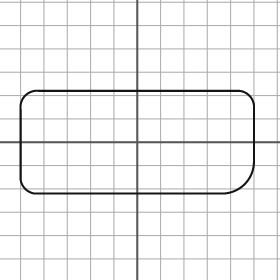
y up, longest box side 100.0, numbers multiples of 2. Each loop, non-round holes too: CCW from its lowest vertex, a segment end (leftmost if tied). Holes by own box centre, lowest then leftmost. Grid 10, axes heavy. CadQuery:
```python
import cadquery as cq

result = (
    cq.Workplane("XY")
    .moveTo(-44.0, -22.0)
    .lineTo(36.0, -22.0)
    .threePointArc((46.0, -18.0), (50.0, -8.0))
    .lineTo(50.0, 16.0)
    .threePointArc((48.0, 20.0), (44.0, 22.0))
    .lineTo(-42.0, 22.0)
    .threePointArc((-48.0, 20.0), (-50.0, 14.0))
    .lineTo(-50.0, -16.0)
    .threePointArc((-48.0, -20.0), (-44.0, -22.0))
    .close()
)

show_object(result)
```